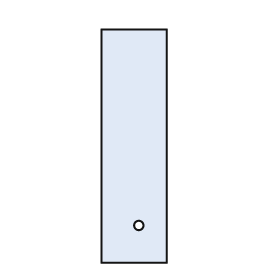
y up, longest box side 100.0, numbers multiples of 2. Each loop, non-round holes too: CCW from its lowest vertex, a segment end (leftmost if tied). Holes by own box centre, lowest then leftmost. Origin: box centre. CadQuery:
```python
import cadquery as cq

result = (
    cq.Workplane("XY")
    .moveTo(-14.0, -50.0)
    .lineTo(14.0, -50.0)
    .lineTo(14.0, 50.0)
    .lineTo(-14.0, 50.0)
    .close()
    .moveTo(2.0, -34.0)
    .circle(2.0)
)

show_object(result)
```